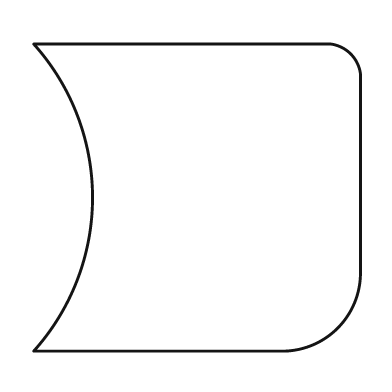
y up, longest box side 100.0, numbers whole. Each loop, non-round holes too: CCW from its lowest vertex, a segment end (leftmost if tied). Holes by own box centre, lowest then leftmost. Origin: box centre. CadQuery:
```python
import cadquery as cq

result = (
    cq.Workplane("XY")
    .moveTo(-50.0, -47.0)
    .lineTo(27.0, -47.0)
    .threePointArc((43.0, -40.0), (50.0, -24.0))
    .lineTo(50.0, 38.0)
    .threePointArc((47.0, 44.0), (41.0, 47.0))
    .lineTo(-50.0, 47.0)
    .threePointArc((-32.0, 0.0), (-50.0, -47.0))
    .close()
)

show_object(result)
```